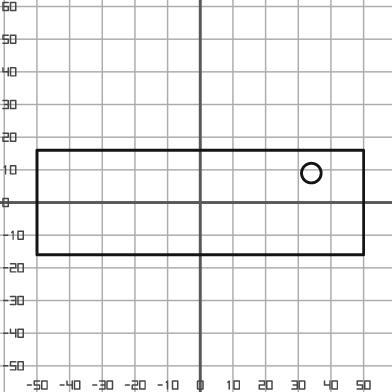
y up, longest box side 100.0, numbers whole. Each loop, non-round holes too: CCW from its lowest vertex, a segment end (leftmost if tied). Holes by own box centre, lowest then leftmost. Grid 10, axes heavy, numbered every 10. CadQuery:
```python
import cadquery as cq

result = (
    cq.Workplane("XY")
    .moveTo(-50.0, -16.0)
    .lineTo(50.0, -16.0)
    .lineTo(50.0, 16.0)
    .lineTo(-50.0, 16.0)
    .close()
    .moveTo(34.0, 9.0)
    .circle(3.0)
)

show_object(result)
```